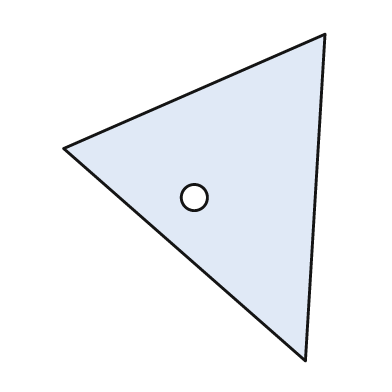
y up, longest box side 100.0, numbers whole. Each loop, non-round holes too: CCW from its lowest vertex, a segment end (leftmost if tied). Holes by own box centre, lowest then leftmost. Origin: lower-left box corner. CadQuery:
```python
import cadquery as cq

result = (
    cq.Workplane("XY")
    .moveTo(74.0, 0.0)
    .lineTo(80.0, 100.0)
    .lineTo(0.0, 65.0)
    .close()
    .moveTo(40.0, 50.0)
    .circle(4.0)
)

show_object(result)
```